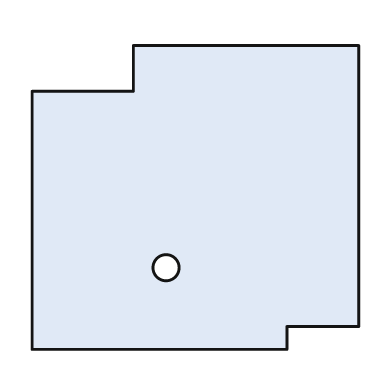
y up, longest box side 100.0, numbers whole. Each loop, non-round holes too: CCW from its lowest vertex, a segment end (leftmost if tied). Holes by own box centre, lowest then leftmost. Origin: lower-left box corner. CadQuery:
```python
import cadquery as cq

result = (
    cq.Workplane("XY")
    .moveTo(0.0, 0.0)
    .lineTo(78.0, 0.0)
    .lineTo(78.0, 7.0)
    .lineTo(100.0, 7.0)
    .lineTo(100.0, 93.0)
    .lineTo(31.0, 93.0)
    .lineTo(31.0, 79.0)
    .lineTo(0.0, 79.0)
    .close()
    .moveTo(41.0, 25.0)
    .circle(4.0)
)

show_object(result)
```